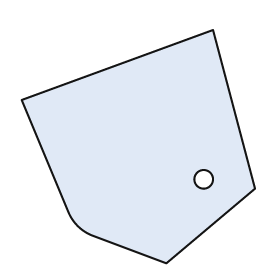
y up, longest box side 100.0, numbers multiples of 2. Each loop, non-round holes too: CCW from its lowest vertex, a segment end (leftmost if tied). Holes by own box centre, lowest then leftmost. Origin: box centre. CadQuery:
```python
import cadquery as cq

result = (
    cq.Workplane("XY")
    .moveTo(12.0, -50.0)
    .lineTo(50.0, -18.0)
    .lineTo(32.0, 50.0)
    .lineTo(-50.0, 20.0)
    .lineTo(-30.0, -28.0)
    .threePointArc((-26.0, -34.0), (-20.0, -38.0))
    .close()
    .moveTo(28.0, -14.0)
    .circle(4.0)
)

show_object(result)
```